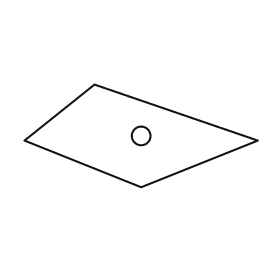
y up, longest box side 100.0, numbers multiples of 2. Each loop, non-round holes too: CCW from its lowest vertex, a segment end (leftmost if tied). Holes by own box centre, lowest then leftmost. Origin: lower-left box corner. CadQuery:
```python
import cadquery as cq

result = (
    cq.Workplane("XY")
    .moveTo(50.0, 0.0)
    .lineTo(100.0, 20.0)
    .lineTo(30.0, 44.0)
    .lineTo(0.0, 20.0)
    .close()
    .moveTo(50.0, 22.0)
    .circle(4.0)
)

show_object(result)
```